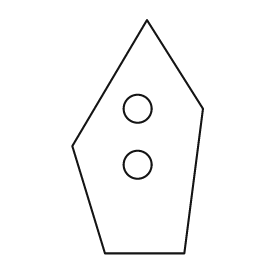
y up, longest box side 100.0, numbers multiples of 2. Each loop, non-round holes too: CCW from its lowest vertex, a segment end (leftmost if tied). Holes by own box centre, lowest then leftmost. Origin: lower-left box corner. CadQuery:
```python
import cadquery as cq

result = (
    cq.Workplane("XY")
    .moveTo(14.0, 0.0)
    .lineTo(48.0, 0.0)
    .lineTo(56.0, 62.0)
    .lineTo(32.0, 100.0)
    .lineTo(0.0, 46.0)
    .close()
    .moveTo(28.0, 38.0)
    .circle(6.0)
    .moveTo(28.0, 62.0)
    .circle(6.0)
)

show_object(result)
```